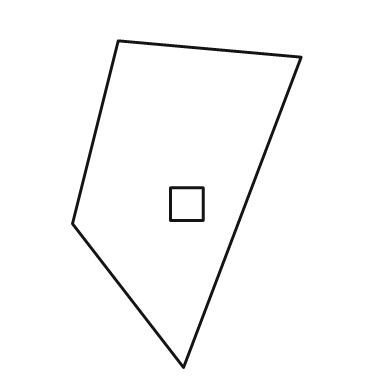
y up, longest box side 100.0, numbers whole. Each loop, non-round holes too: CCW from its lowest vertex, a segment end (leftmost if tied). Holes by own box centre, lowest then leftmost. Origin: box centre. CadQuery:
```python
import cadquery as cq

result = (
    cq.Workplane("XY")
    .moveTo(-1.0, -50.0)
    .lineTo(35.0, 45.0)
    .lineTo(-21.0, 50.0)
    .lineTo(-35.0, -6.0)
    .close()
    .moveTo(-5.0, -5.0)
    .lineTo(5.0, -5.0)
    .lineTo(5.0, 5.0)
    .lineTo(-5.0, 5.0)
    .close()
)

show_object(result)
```